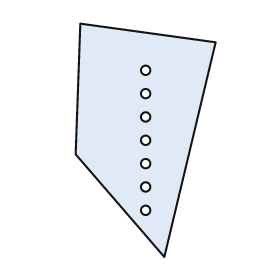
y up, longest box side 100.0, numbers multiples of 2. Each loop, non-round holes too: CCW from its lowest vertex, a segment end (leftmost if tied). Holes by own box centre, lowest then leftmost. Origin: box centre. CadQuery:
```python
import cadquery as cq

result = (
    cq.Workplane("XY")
    .moveTo(8.0, -50.0)
    .lineTo(30.0, 42.0)
    .lineTo(-28.0, 50.0)
    .lineTo(-30.0, -6.0)
    .close()
    .moveTo(0.0, -30.0)
    .circle(2.0)
    .moveTo(0.0, -20.0)
    .circle(2.0)
    .moveTo(0.0, -10.0)
    .circle(2.0)
    .moveTo(0.0, 0.0)
    .circle(2.0)
    .moveTo(0.0, 10.0)
    .circle(2.0)
    .moveTo(0.0, 20.0)
    .circle(2.0)
    .moveTo(0.0, 30.0)
    .circle(2.0)
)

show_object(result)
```